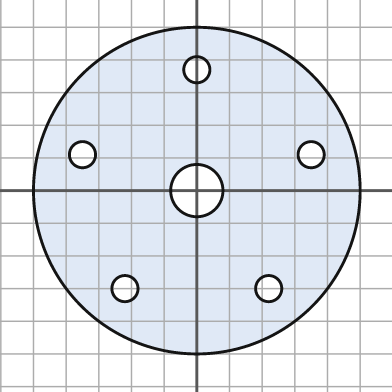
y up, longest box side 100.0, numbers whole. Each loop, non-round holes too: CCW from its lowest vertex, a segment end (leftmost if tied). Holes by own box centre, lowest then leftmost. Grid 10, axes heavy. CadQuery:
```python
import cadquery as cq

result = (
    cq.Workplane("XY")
    .moveTo(0.0, 0.0)
    .circle(50.0)
    .moveTo(-22.0, -30.0)
    .circle(4.0)
    .moveTo(22.0, -30.0)
    .circle(4.0)
    .moveTo(0.0, 0.0)
    .circle(8.0)
    .moveTo(-35.0, 11.0)
    .circle(4.0)
    .moveTo(35.0, 11.0)
    .circle(4.0)
    .moveTo(0.0, 37.0)
    .circle(4.0)
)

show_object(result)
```